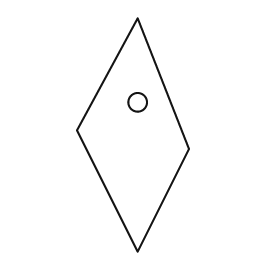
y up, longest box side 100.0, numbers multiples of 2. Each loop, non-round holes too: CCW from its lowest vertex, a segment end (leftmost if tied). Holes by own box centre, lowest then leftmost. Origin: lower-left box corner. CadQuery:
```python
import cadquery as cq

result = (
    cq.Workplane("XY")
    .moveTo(26.0, 0.0)
    .lineTo(48.0, 44.0)
    .lineTo(26.0, 100.0)
    .lineTo(0.0, 52.0)
    .close()
    .moveTo(26.0, 64.0)
    .circle(4.0)
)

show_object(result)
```